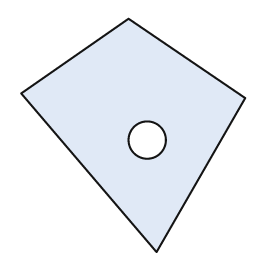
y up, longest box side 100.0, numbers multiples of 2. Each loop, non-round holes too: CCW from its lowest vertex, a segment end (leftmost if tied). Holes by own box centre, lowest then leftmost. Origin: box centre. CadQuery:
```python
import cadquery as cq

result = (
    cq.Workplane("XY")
    .moveTo(10.0, -50.0)
    .lineTo(48.0, 16.0)
    .lineTo(-2.0, 50.0)
    .lineTo(-48.0, 18.0)
    .close()
    .moveTo(6.0, -2.0)
    .circle(8.0)
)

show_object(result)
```